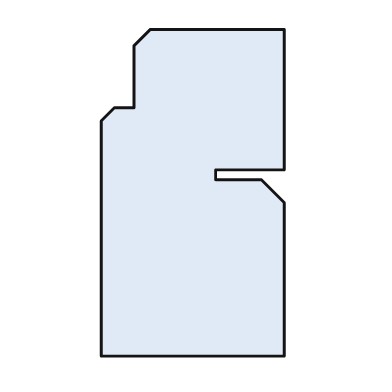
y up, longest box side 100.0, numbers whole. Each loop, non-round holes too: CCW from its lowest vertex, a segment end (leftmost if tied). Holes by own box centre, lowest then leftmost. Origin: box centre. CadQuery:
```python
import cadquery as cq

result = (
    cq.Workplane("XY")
    .moveTo(-28.0, -50.0)
    .lineTo(28.0, -50.0)
    .lineTo(28.0, -3.0)
    .lineTo(21.0, 4.0)
    .lineTo(7.0, 4.0)
    .lineTo(7.0, 7.0)
    .lineTo(28.0, 7.0)
    .lineTo(28.0, 50.0)
    .lineTo(-13.0, 50.0)
    .lineTo(-18.0, 45.0)
    .lineTo(-18.0, 26.0)
    .lineTo(-24.0, 26.0)
    .lineTo(-28.0, 22.0)
    .close()
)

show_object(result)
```